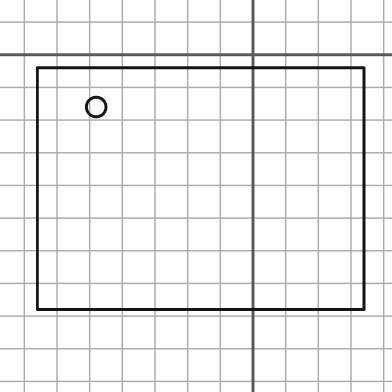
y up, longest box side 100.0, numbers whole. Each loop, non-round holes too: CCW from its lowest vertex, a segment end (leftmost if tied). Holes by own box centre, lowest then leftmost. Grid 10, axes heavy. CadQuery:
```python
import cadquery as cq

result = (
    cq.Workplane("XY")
    .moveTo(-66.0, -78.0)
    .lineTo(34.0, -78.0)
    .lineTo(34.0, -4.0)
    .lineTo(-66.0, -4.0)
    .close()
    .moveTo(-48.0, -16.0)
    .circle(3.0)
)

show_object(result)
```